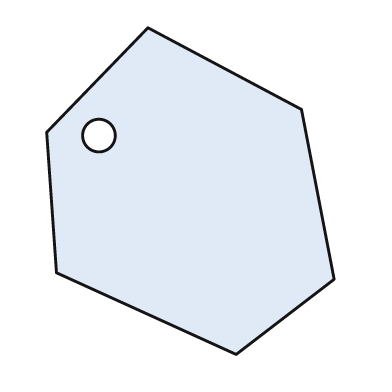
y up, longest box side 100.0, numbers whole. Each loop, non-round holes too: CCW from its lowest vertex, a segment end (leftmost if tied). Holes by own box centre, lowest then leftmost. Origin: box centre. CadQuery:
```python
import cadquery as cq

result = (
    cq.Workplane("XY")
    .moveTo(14.0, -50.0)
    .lineTo(44.0, -27.0)
    .lineTo(34.0, 25.0)
    .lineTo(-13.0, 50.0)
    .lineTo(-44.0, 18.0)
    .lineTo(-41.0, -25.0)
    .close()
    .moveTo(-28.0, 17.0)
    .circle(5.0)
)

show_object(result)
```